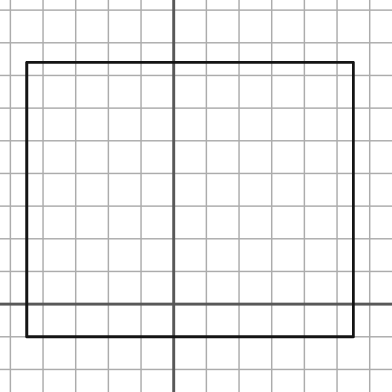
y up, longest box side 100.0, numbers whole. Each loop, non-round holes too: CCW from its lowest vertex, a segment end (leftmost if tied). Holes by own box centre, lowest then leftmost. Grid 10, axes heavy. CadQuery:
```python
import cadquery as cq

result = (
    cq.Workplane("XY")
    .moveTo(-45.0, -10.0)
    .lineTo(55.0, -10.0)
    .lineTo(55.0, 74.0)
    .lineTo(-45.0, 74.0)
    .close()
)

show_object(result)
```